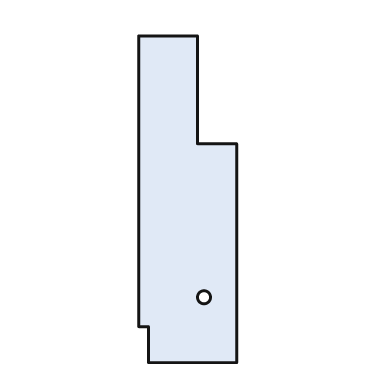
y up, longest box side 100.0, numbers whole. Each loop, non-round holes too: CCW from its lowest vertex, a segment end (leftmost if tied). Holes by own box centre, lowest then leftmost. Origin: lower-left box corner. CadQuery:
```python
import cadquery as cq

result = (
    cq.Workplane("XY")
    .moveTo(3.0, 0.0)
    .lineTo(30.0, 0.0)
    .lineTo(30.0, 67.0)
    .lineTo(18.0, 67.0)
    .lineTo(18.0, 100.0)
    .lineTo(0.0, 100.0)
    .lineTo(0.0, 11.0)
    .lineTo(3.0, 11.0)
    .close()
    .moveTo(20.0, 20.0)
    .circle(2.0)
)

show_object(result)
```